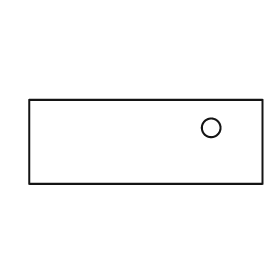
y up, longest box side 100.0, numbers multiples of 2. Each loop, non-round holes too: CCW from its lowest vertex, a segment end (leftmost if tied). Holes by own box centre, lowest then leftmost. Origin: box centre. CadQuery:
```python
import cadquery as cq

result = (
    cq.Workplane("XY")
    .moveTo(-50.0, -18.0)
    .lineTo(50.0, -18.0)
    .lineTo(50.0, 18.0)
    .lineTo(-50.0, 18.0)
    .close()
    .moveTo(28.0, 6.0)
    .circle(4.0)
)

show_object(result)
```